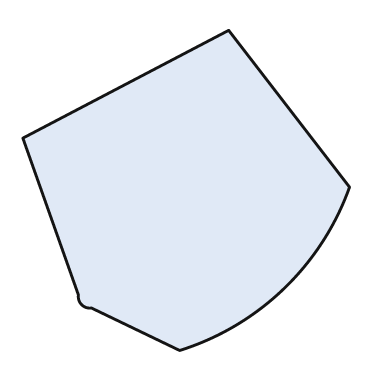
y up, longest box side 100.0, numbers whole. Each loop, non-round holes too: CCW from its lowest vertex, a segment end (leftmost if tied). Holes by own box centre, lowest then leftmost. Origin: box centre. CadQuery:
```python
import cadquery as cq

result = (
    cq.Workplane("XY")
    .moveTo(-2.0, -49.0)
    .threePointArc((30.0, -30.0), (50.0, 1.0))
    .lineTo(13.0, 49.0)
    .lineTo(-50.0, 16.0)
    .lineTo(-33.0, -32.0)
    .threePointArc((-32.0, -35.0), (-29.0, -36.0))
    .close()
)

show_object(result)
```